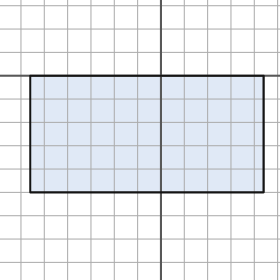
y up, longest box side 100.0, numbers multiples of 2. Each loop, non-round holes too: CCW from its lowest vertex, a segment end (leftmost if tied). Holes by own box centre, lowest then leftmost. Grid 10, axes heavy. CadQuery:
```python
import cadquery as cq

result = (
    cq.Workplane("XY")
    .moveTo(-56.0, -50.0)
    .lineTo(44.0, -50.0)
    .lineTo(44.0, 0.0)
    .lineTo(-56.0, 0.0)
    .close()
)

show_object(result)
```